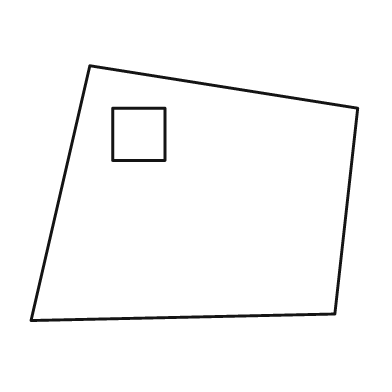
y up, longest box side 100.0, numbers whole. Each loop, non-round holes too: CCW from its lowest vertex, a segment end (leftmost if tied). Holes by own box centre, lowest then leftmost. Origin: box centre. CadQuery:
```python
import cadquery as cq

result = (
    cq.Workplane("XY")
    .moveTo(-50.0, -39.0)
    .lineTo(43.0, -37.0)
    .lineTo(50.0, 26.0)
    .lineTo(-32.0, 39.0)
    .close()
    .moveTo(-25.0, 10.0)
    .lineTo(-9.0, 10.0)
    .lineTo(-9.0, 26.0)
    .lineTo(-25.0, 26.0)
    .close()
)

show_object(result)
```